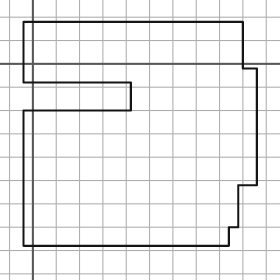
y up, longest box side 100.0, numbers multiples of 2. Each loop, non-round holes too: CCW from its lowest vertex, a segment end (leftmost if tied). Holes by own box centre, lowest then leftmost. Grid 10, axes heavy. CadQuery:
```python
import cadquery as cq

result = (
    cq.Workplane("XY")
    .moveTo(-4.0, -78.0)
    .lineTo(84.0, -78.0)
    .lineTo(84.0, -70.0)
    .lineTo(88.0, -70.0)
    .lineTo(88.0, -52.0)
    .lineTo(96.0, -52.0)
    .lineTo(96.0, -2.0)
    .lineTo(90.0, -2.0)
    .lineTo(90.0, 18.0)
    .lineTo(-4.0, 18.0)
    .lineTo(-4.0, -8.0)
    .lineTo(42.0, -8.0)
    .lineTo(42.0, -20.0)
    .lineTo(-4.0, -20.0)
    .close()
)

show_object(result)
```